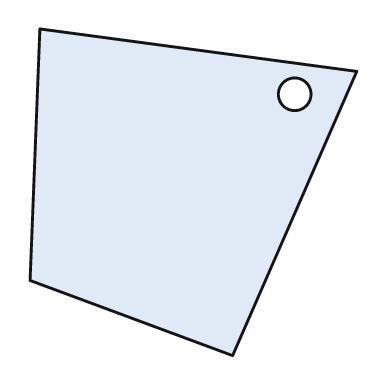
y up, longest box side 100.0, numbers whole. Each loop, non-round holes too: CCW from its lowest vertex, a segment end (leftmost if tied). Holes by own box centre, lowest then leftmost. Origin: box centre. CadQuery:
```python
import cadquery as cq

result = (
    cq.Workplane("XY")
    .moveTo(12.0, -50.0)
    .lineTo(50.0, 37.0)
    .lineTo(-47.0, 50.0)
    .lineTo(-50.0, -27.0)
    .close()
    .moveTo(31.0, 30.0)
    .circle(5.0)
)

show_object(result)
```